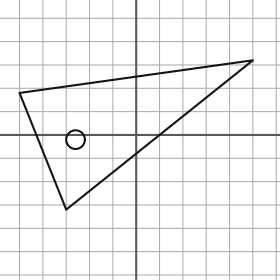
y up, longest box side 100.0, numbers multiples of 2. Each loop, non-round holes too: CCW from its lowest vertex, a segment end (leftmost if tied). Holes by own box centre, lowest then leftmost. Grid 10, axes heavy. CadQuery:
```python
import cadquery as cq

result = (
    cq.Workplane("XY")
    .moveTo(-30.0, -32.0)
    .lineTo(50.0, 32.0)
    .lineTo(-50.0, 18.0)
    .close()
    .moveTo(-26.0, -2.0)
    .circle(4.0)
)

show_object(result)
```